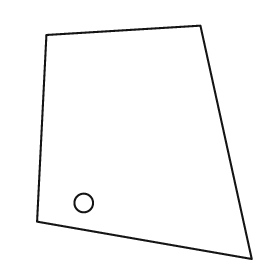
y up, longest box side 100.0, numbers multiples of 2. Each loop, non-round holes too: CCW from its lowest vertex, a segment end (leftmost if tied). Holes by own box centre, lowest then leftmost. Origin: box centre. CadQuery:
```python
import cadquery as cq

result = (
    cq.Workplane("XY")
    .moveTo(46.0, -50.0)
    .lineTo(24.0, 50.0)
    .lineTo(-42.0, 46.0)
    .lineTo(-46.0, -34.0)
    .close()
    .moveTo(-26.0, -26.0)
    .circle(4.0)
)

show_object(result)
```